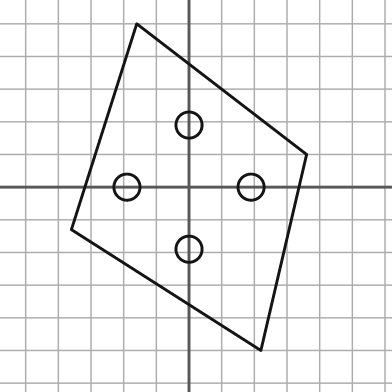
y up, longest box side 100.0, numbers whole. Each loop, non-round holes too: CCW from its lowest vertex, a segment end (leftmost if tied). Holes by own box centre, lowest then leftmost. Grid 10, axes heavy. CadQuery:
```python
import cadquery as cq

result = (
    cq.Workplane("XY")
    .moveTo(22.0, -50.0)
    .lineTo(36.0, 10.0)
    .lineTo(-16.0, 50.0)
    .lineTo(-36.0, -13.0)
    .close()
    .moveTo(0.0, -19.0)
    .circle(4.0)
    .moveTo(-19.0, 0.0)
    .circle(4.0)
    .moveTo(19.0, 0.0)
    .circle(4.0)
    .moveTo(0.0, 19.0)
    .circle(4.0)
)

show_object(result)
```